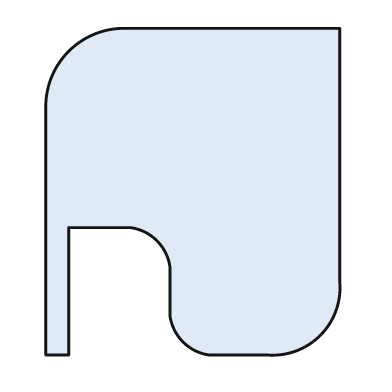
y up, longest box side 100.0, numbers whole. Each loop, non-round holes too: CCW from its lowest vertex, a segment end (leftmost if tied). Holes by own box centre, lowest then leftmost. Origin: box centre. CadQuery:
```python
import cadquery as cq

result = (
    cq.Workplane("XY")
    .moveTo(-45.0, -50.0)
    .lineTo(-38.0, -50.0)
    .lineTo(-38.0, -11.0)
    .lineTo(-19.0, -11.0)
    .threePointArc((-11.0, -15.0), (-7.0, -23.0))
    .lineTo(-7.0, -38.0)
    .threePointArc((-3.0, -46.0), (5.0, -50.0))
    .lineTo(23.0, -50.0)
    .threePointArc((39.0, -44.0), (45.0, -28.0))
    .lineTo(45.0, 50.0)
    .lineTo(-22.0, 50.0)
    .threePointArc((-38.0, 43.0), (-45.0, 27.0))
    .close()
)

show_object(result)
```